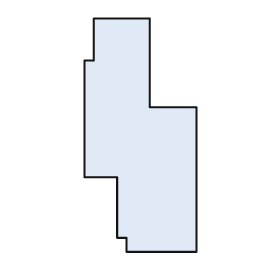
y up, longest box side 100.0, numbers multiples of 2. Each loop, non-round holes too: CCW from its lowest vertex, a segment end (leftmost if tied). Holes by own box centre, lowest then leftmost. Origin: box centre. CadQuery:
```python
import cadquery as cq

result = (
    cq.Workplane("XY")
    .moveTo(-6.0, -50.0)
    .lineTo(24.0, -50.0)
    .lineTo(24.0, 12.0)
    .lineTo(4.0, 12.0)
    .lineTo(4.0, 50.0)
    .lineTo(-20.0, 50.0)
    .lineTo(-20.0, 32.0)
    .lineTo(-24.0, 32.0)
    .lineTo(-24.0, -18.0)
    .lineTo(-10.0, -18.0)
    .lineTo(-10.0, -44.0)
    .lineTo(-6.0, -44.0)
    .close()
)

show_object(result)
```